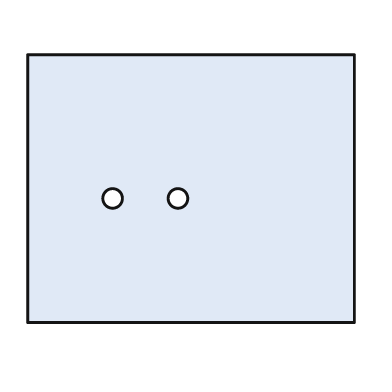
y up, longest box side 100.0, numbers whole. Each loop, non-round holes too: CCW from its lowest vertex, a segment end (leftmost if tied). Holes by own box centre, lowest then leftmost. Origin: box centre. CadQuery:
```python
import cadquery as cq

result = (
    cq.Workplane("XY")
    .moveTo(-50.0, -41.0)
    .lineTo(50.0, -41.0)
    .lineTo(50.0, 41.0)
    .lineTo(-50.0, 41.0)
    .close()
    .moveTo(-24.0, -3.0)
    .circle(3.0)
    .moveTo(-4.0, -3.0)
    .circle(3.0)
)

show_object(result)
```